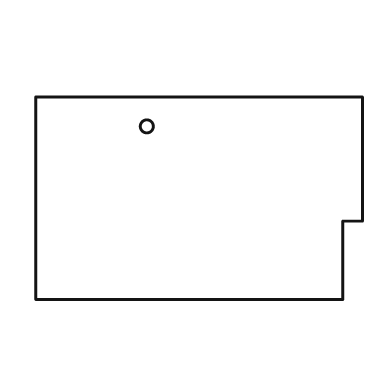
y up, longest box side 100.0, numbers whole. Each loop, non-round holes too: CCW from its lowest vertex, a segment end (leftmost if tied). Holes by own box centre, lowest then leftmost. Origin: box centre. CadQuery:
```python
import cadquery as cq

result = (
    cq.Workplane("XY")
    .moveTo(-50.0, -31.0)
    .lineTo(44.0, -31.0)
    .lineTo(44.0, -7.0)
    .lineTo(50.0, -7.0)
    .lineTo(50.0, 31.0)
    .lineTo(-50.0, 31.0)
    .close()
    .moveTo(-16.0, 22.0)
    .circle(2.0)
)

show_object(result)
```